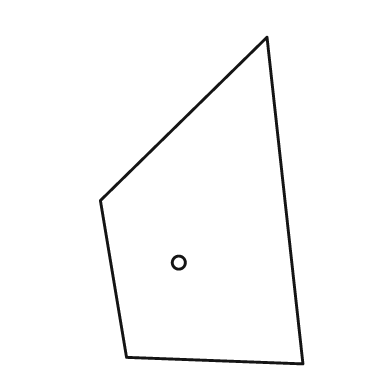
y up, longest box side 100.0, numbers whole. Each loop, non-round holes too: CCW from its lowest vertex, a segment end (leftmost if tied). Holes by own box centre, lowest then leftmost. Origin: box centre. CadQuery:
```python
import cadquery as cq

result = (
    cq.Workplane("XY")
    .moveTo(31.0, -50.0)
    .lineTo(20.0, 50.0)
    .lineTo(-31.0, 0.0)
    .lineTo(-23.0, -48.0)
    .close()
    .moveTo(-7.0, -19.0)
    .circle(2.0)
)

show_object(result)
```